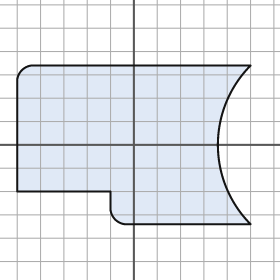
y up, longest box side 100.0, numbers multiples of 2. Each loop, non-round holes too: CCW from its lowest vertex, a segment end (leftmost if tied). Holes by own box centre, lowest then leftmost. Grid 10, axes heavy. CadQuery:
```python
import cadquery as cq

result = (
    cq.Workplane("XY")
    .moveTo(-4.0, -34.0)
    .lineTo(50.0, -34.0)
    .threePointArc((36.0, 0.0), (50.0, 34.0))
    .lineTo(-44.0, 34.0)
    .threePointArc((-48.0, 32.0), (-50.0, 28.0))
    .lineTo(-50.0, -20.0)
    .lineTo(-10.0, -20.0)
    .lineTo(-10.0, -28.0)
    .threePointArc((-8.0, -32.0), (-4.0, -34.0))
    .close()
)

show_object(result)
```